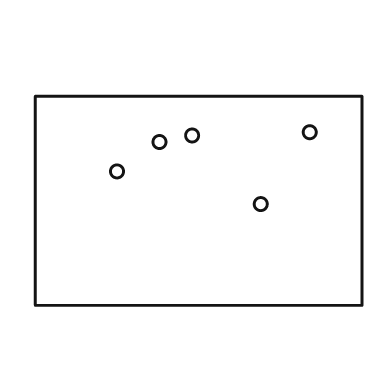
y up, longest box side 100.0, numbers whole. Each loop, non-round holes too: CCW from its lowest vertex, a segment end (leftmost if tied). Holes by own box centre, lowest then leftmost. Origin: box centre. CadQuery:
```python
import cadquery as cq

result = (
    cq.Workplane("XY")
    .moveTo(-50.0, -32.0)
    .lineTo(50.0, -32.0)
    .lineTo(50.0, 32.0)
    .lineTo(-50.0, 32.0)
    .close()
    .moveTo(19.0, -1.0)
    .circle(2.0)
    .moveTo(-25.0, 9.0)
    .circle(2.0)
    .moveTo(-12.0, 18.0)
    .circle(2.0)
    .moveTo(-2.0, 20.0)
    .circle(2.0)
    .moveTo(34.0, 21.0)
    .circle(2.0)
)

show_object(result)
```